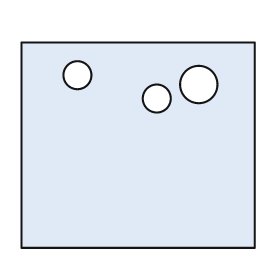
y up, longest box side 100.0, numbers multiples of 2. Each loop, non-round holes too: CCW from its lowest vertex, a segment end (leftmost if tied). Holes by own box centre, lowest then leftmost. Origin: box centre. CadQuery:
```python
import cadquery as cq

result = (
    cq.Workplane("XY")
    .moveTo(-50.0, -44.0)
    .lineTo(50.0, -44.0)
    .lineTo(50.0, 44.0)
    .lineTo(-50.0, 44.0)
    .close()
    .moveTo(8.0, 20.0)
    .circle(6.0)
    .moveTo(26.0, 26.0)
    .circle(8.0)
    .moveTo(-26.0, 30.0)
    .circle(6.0)
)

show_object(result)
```